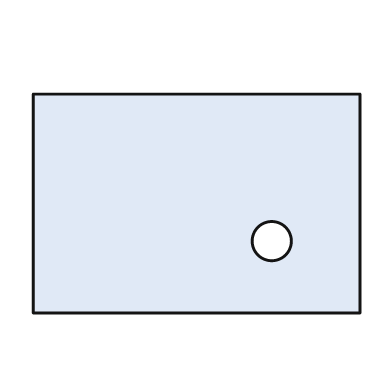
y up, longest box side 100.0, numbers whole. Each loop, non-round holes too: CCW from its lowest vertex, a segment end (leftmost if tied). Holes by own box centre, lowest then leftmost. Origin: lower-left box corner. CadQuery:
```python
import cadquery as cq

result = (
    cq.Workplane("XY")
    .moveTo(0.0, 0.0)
    .lineTo(100.0, 0.0)
    .lineTo(100.0, 67.0)
    .lineTo(0.0, 67.0)
    .close()
    .moveTo(73.0, 22.0)
    .circle(6.0)
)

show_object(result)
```